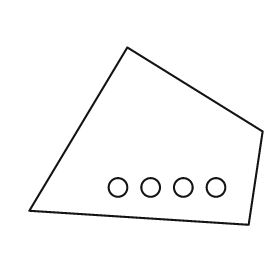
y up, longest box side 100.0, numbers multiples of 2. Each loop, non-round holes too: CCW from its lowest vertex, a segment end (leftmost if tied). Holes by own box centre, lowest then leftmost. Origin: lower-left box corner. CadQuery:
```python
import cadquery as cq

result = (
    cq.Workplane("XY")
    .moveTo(94.0, 0.0)
    .lineTo(100.0, 40.0)
    .lineTo(42.0, 76.0)
    .lineTo(0.0, 6.0)
    .close()
    .moveTo(38.0, 16.0)
    .circle(4.0)
    .moveTo(52.0, 16.0)
    .circle(4.0)
    .moveTo(66.0, 16.0)
    .circle(4.0)
    .moveTo(80.0, 16.0)
    .circle(4.0)
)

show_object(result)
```